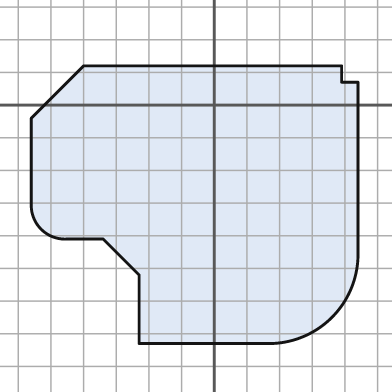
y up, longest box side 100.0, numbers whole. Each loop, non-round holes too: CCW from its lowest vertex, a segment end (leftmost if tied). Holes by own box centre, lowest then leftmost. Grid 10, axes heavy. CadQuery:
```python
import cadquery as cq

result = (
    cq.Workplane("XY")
    .moveTo(-23.0, -73.0)
    .lineTo(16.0, -73.0)
    .threePointArc((36.0, -65.0), (44.0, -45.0))
    .lineTo(44.0, 7.0)
    .lineTo(39.0, 7.0)
    .lineTo(39.0, 12.0)
    .lineTo(-40.0, 12.0)
    .lineTo(-56.0, -4.0)
    .lineTo(-56.0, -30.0)
    .threePointArc((-53.0, -38.0), (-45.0, -41.0))
    .lineTo(-34.0, -41.0)
    .lineTo(-23.0, -52.0)
    .close()
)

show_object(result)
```